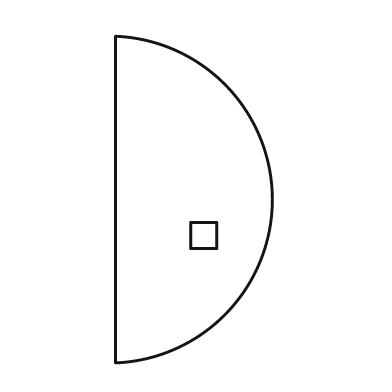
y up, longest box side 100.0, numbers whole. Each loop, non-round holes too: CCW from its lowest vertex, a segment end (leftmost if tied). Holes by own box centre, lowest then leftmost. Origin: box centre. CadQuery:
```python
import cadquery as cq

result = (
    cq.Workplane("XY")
    .moveTo(-24.0, -50.0)
    .threePointArc((24.0, 0.0), (-24.0, 50.0))
    .close()
    .moveTo(-1.0, -15.0)
    .lineTo(7.0, -15.0)
    .lineTo(7.0, -7.0)
    .lineTo(-1.0, -7.0)
    .close()
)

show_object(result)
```